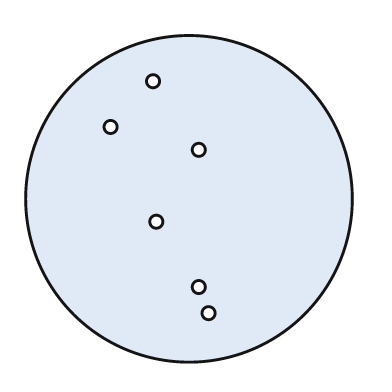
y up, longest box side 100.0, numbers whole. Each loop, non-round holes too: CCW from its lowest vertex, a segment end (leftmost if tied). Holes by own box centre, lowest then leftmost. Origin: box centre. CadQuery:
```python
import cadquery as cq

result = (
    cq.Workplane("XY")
    .moveTo(0.0, 0.0)
    .circle(50.0)
    .moveTo(6.0, -35.0)
    .circle(2.0)
    .moveTo(3.0, -27.0)
    .circle(2.0)
    .moveTo(-10.0, -7.0)
    .circle(2.0)
    .moveTo(3.0, 15.0)
    .circle(2.0)
    .moveTo(-24.0, 22.0)
    .circle(2.0)
    .moveTo(-11.0, 36.0)
    .circle(2.0)
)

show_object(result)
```